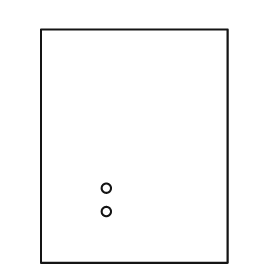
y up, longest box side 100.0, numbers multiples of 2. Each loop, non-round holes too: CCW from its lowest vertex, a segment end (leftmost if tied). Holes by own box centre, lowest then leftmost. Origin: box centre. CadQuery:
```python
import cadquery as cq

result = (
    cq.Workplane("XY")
    .moveTo(-40.0, -50.0)
    .lineTo(40.0, -50.0)
    .lineTo(40.0, 50.0)
    .lineTo(-40.0, 50.0)
    .close()
    .moveTo(-12.0, -28.0)
    .circle(2.0)
    .moveTo(-12.0, -18.0)
    .circle(2.0)
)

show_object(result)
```